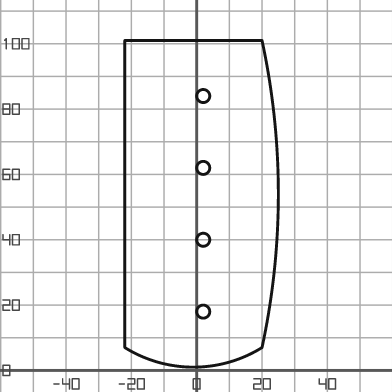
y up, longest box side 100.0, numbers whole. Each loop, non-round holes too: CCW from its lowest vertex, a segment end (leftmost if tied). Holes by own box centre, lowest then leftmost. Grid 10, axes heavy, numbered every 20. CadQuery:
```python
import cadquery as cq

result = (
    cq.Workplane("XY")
    .moveTo(-22.0, 7.0)
    .threePointArc((-1.0, 1.0), (20.0, 7.0))
    .threePointArc((25.0, 54.0), (20.0, 101.0))
    .lineTo(-22.0, 101.0)
    .close()
    .moveTo(2.0, 18.0)
    .circle(2.0)
    .moveTo(2.0, 40.0)
    .circle(2.0)
    .moveTo(2.0, 62.0)
    .circle(2.0)
    .moveTo(2.0, 84.0)
    .circle(2.0)
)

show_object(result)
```